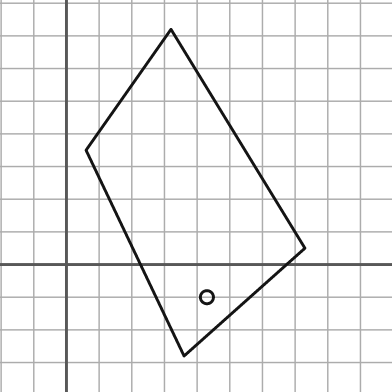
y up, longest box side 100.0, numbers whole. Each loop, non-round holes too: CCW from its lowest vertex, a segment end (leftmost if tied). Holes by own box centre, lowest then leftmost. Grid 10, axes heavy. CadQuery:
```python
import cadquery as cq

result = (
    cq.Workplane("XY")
    .moveTo(36.0, -28.0)
    .lineTo(73.0, 5.0)
    .lineTo(32.0, 72.0)
    .lineTo(6.0, 35.0)
    .close()
    .moveTo(43.0, -10.0)
    .circle(2.0)
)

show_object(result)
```